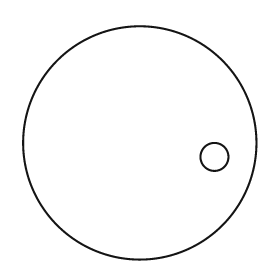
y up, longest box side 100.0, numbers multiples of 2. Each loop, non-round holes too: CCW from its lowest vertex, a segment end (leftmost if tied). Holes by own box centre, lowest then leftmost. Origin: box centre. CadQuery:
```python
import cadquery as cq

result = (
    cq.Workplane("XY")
    .moveTo(0.0, 0.0)
    .circle(50.0)
    .moveTo(32.0, -6.0)
    .circle(6.0)
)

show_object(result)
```